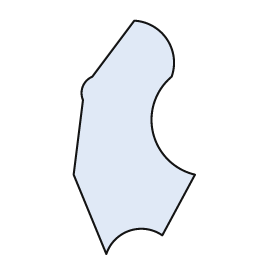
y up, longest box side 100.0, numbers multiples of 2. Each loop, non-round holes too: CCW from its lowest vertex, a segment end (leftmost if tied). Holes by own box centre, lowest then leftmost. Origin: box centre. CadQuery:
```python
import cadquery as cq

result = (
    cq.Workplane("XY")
    .moveTo(-12.0, -50.0)
    .threePointArc((-2.0, -40.0), (12.0, -42.0))
    .lineTo(26.0, -16.0)
    .threePointArc((8.0, 2.0), (16.0, 26.0))
    .threePointArc((14.0, 42.0), (0.0, 50.0))
    .lineTo(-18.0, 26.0)
    .threePointArc((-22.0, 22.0), (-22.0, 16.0))
    .lineTo(-26.0, -16.0)
    .close()
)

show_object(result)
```